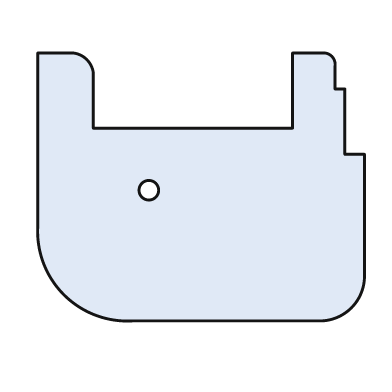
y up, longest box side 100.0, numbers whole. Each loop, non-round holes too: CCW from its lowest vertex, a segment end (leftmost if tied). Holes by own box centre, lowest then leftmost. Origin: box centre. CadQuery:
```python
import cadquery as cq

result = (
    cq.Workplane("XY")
    .moveTo(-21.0, -41.0)
    .lineTo(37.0, -41.0)
    .threePointArc((46.0, -37.0), (50.0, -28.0))
    .lineTo(50.0, 10.0)
    .lineTo(44.0, 10.0)
    .lineTo(44.0, 30.0)
    .lineTo(41.0, 30.0)
    .lineTo(41.0, 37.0)
    .threePointArc((40.0, 40.0), (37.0, 41.0))
    .lineTo(28.0, 41.0)
    .lineTo(28.0, 18.0)
    .lineTo(-33.0, 18.0)
    .lineTo(-33.0, 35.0)
    .threePointArc((-35.0, 39.0), (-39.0, 41.0))
    .lineTo(-50.0, 41.0)
    .lineTo(-50.0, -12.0)
    .threePointArc((-42.0, -33.0), (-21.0, -41.0))
    .close()
    .moveTo(-16.0, -1.0)
    .circle(3.0)
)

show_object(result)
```